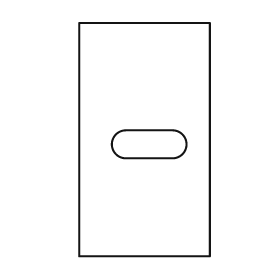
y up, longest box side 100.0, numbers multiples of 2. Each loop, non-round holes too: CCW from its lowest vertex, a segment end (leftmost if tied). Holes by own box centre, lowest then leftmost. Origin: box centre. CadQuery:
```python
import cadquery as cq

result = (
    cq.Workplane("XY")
    .moveTo(-28.0, -50.0)
    .lineTo(28.0, -50.0)
    .lineTo(28.0, 50.0)
    .lineTo(-28.0, 50.0)
    .close()
    .moveTo(-8.0, -8.0)
    .lineTo(12.0, -8.0)
    .threePointArc((18.0, -2.0), (12.0, 4.0))
    .lineTo(-8.0, 4.0)
    .threePointArc((-14.0, -2.0), (-8.0, -8.0))
    .close()
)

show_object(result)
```